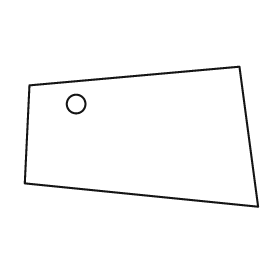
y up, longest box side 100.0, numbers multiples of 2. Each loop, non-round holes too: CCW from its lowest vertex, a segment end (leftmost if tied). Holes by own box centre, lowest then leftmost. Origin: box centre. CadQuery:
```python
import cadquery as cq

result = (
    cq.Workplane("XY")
    .moveTo(50.0, -30.0)
    .lineTo(42.0, 30.0)
    .lineTo(-48.0, 22.0)
    .lineTo(-50.0, -20.0)
    .close()
    .moveTo(-28.0, 14.0)
    .circle(4.0)
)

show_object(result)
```